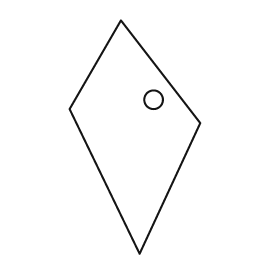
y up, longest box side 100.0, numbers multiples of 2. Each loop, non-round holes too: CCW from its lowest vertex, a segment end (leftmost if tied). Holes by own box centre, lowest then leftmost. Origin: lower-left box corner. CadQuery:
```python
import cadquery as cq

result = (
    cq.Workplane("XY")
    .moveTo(30.0, 0.0)
    .lineTo(56.0, 56.0)
    .lineTo(22.0, 100.0)
    .lineTo(0.0, 62.0)
    .close()
    .moveTo(36.0, 66.0)
    .circle(4.0)
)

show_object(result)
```